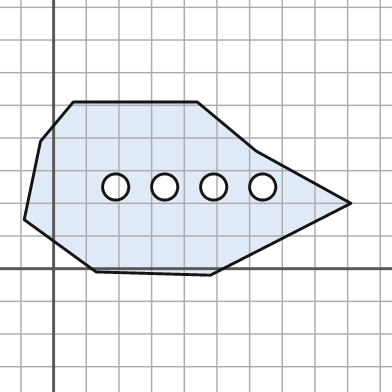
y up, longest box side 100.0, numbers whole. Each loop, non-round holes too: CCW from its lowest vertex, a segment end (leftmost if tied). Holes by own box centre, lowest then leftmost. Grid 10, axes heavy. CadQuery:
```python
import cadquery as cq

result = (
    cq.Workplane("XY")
    .moveTo(48.0, -2.0)
    .lineTo(91.0, 20.0)
    .lineTo(62.0, 36.0)
    .lineTo(44.0, 51.0)
    .lineTo(6.0, 51.0)
    .lineTo(-4.0, 39.0)
    .lineTo(-9.0, 15.0)
    .lineTo(13.0, -1.0)
    .close()
    .moveTo(19.0, 25.0)
    .circle(4.0)
    .moveTo(34.0, 25.0)
    .circle(4.0)
    .moveTo(49.0, 25.0)
    .circle(4.0)
    .moveTo(64.0, 25.0)
    .circle(4.0)
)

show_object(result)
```